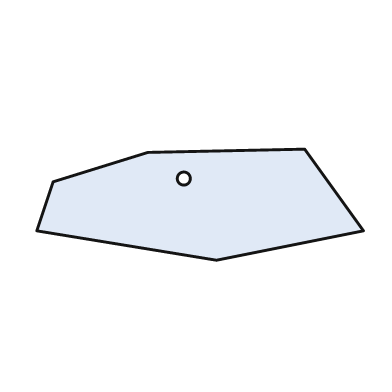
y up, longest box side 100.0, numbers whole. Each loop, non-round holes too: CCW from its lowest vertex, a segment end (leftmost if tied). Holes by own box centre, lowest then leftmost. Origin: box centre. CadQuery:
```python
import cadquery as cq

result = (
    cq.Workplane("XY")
    .moveTo(5.0, -17.0)
    .lineTo(50.0, -8.0)
    .lineTo(32.0, 17.0)
    .lineTo(-16.0, 16.0)
    .lineTo(-45.0, 7.0)
    .lineTo(-50.0, -8.0)
    .close()
    .moveTo(-5.0, 8.0)
    .circle(2.0)
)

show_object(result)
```